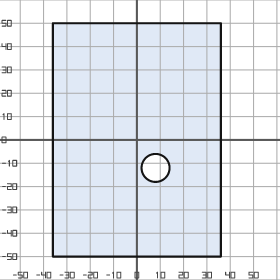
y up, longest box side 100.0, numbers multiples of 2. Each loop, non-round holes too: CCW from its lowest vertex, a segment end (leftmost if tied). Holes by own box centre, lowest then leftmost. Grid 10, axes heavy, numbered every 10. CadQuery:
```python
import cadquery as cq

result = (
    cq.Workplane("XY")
    .moveTo(-36.0, -50.0)
    .lineTo(36.0, -50.0)
    .lineTo(36.0, 50.0)
    .lineTo(-36.0, 50.0)
    .close()
    .moveTo(8.0, -12.0)
    .circle(6.0)
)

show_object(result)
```